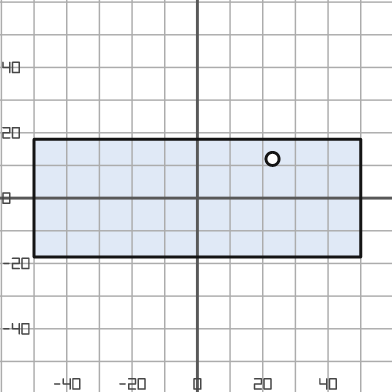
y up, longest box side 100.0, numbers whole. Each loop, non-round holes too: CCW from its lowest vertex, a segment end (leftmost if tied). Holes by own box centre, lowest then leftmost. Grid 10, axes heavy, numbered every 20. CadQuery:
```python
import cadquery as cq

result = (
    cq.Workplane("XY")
    .moveTo(-50.0, -18.0)
    .lineTo(50.0, -18.0)
    .lineTo(50.0, 18.0)
    .lineTo(-50.0, 18.0)
    .close()
    .moveTo(23.0, 12.0)
    .circle(2.0)
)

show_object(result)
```